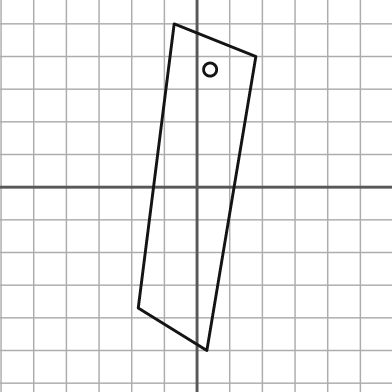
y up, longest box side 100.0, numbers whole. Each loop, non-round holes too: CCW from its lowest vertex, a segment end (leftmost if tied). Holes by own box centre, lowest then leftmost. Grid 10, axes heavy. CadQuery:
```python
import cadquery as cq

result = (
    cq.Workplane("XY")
    .moveTo(3.0, -50.0)
    .lineTo(18.0, 40.0)
    .lineTo(-7.0, 50.0)
    .lineTo(-18.0, -37.0)
    .close()
    .moveTo(4.0, 36.0)
    .circle(2.0)
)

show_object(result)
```